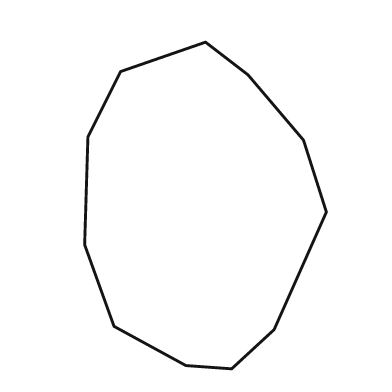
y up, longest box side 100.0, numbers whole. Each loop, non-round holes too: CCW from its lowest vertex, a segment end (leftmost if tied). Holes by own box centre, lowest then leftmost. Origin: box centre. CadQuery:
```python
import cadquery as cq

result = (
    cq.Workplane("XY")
    .moveTo(8.0, -50.0)
    .lineTo(21.0, -38.0)
    .lineTo(37.0, -2.0)
    .lineTo(30.0, 20.0)
    .lineTo(13.0, 40.0)
    .lineTo(0.0, 50.0)
    .lineTo(-26.0, 41.0)
    .lineTo(-36.0, 21.0)
    .lineTo(-37.0, -12.0)
    .lineTo(-28.0, -37.0)
    .lineTo(-6.0, -49.0)
    .close()
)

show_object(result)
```